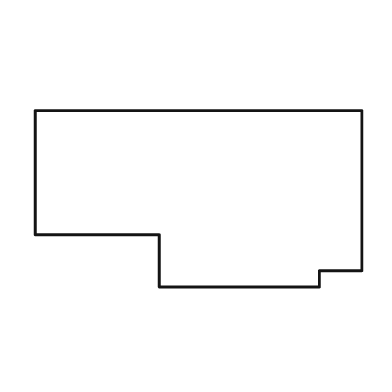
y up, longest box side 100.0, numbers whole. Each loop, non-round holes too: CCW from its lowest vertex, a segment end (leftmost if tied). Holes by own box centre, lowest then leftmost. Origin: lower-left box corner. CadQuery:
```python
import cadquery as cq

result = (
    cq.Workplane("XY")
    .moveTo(38.0, 0.0)
    .lineTo(87.0, 0.0)
    .lineTo(87.0, 5.0)
    .lineTo(100.0, 5.0)
    .lineTo(100.0, 54.0)
    .lineTo(0.0, 54.0)
    .lineTo(0.0, 16.0)
    .lineTo(38.0, 16.0)
    .close()
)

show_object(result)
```